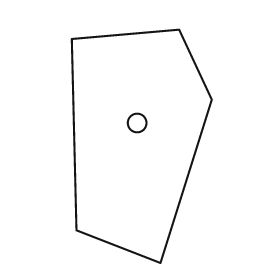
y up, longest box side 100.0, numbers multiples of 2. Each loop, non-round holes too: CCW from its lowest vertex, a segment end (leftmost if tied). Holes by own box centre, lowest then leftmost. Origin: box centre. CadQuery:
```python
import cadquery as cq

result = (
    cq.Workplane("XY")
    .moveTo(8.0, -50.0)
    .lineTo(30.0, 20.0)
    .lineTo(16.0, 50.0)
    .lineTo(-30.0, 46.0)
    .lineTo(-28.0, -36.0)
    .close()
    .moveTo(-2.0, 10.0)
    .circle(4.0)
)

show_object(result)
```